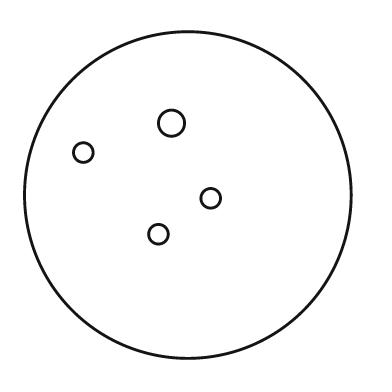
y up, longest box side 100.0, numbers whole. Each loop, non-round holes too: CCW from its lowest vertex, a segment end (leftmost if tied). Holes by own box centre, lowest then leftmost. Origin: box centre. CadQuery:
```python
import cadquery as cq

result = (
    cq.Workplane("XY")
    .moveTo(0.0, 0.0)
    .circle(50.0)
    .moveTo(-9.0, -12.0)
    .circle(3.0)
    .moveTo(7.0, -1.0)
    .circle(3.0)
    .moveTo(-32.0, 13.0)
    .circle(3.0)
    .moveTo(-5.0, 22.0)
    .circle(4.0)
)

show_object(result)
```